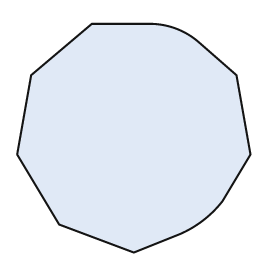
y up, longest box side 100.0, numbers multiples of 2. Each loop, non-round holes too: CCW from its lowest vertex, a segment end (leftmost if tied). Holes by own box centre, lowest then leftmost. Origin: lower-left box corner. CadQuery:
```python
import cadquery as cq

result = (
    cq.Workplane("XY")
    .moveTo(50.0, 0.0)
    .lineTo(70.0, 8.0)
    .threePointArc((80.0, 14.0), (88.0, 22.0))
    .lineTo(100.0, 42.0)
    .lineTo(94.0, 76.0)
    .lineTo(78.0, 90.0)
    .threePointArc((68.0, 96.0), (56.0, 98.0))
    .lineTo(32.0, 98.0)
    .lineTo(6.0, 76.0)
    .lineTo(0.0, 42.0)
    .lineTo(18.0, 12.0)
    .close()
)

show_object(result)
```